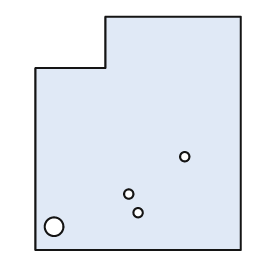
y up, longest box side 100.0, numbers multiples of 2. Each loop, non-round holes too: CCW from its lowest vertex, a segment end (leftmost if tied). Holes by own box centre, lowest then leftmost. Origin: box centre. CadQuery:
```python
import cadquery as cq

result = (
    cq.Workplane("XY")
    .moveTo(-44.0, -50.0)
    .lineTo(44.0, -50.0)
    .lineTo(44.0, 50.0)
    .lineTo(-14.0, 50.0)
    .lineTo(-14.0, 28.0)
    .lineTo(-44.0, 28.0)
    .close()
    .moveTo(-36.0, -40.0)
    .circle(4.0)
    .moveTo(0.0, -34.0)
    .circle(2.0)
    .moveTo(-4.0, -26.0)
    .circle(2.0)
    .moveTo(20.0, -10.0)
    .circle(2.0)
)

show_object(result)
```